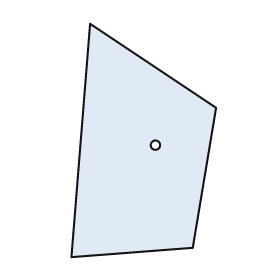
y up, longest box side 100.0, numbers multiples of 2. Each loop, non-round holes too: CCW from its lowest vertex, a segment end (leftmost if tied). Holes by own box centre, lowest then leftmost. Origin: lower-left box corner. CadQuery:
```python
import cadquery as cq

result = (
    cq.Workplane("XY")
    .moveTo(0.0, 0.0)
    .lineTo(52.0, 4.0)
    .lineTo(62.0, 64.0)
    .lineTo(8.0, 100.0)
    .close()
    .moveTo(36.0, 48.0)
    .circle(2.0)
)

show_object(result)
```